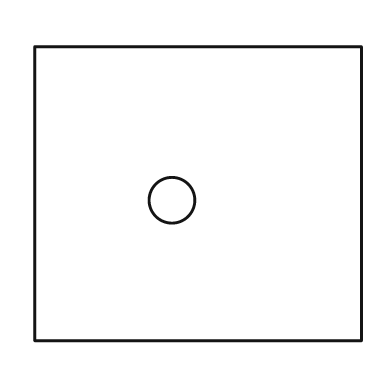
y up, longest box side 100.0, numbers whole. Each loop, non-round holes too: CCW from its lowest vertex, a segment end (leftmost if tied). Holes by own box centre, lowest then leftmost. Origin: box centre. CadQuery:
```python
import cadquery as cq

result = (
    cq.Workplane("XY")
    .moveTo(-50.0, -45.0)
    .lineTo(50.0, -45.0)
    .lineTo(50.0, 45.0)
    .lineTo(-50.0, 45.0)
    .close()
    .moveTo(-8.0, -2.0)
    .circle(7.0)
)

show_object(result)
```